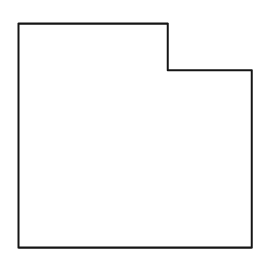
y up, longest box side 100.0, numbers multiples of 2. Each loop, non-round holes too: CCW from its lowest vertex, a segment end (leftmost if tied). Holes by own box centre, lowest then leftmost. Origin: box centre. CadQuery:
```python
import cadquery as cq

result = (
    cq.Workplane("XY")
    .moveTo(-50.0, -48.0)
    .lineTo(50.0, -48.0)
    .lineTo(50.0, 28.0)
    .lineTo(14.0, 28.0)
    .lineTo(14.0, 48.0)
    .lineTo(-50.0, 48.0)
    .close()
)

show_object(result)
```